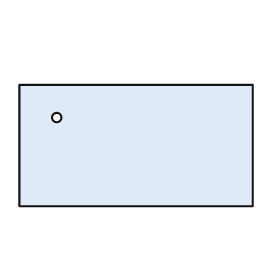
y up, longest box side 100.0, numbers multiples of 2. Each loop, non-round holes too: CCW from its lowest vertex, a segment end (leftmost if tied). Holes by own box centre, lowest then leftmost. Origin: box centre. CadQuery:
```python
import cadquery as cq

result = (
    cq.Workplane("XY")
    .moveTo(-50.0, -26.0)
    .lineTo(50.0, -26.0)
    .lineTo(50.0, 26.0)
    .lineTo(-50.0, 26.0)
    .close()
    .moveTo(-34.0, 12.0)
    .circle(2.0)
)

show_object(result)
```